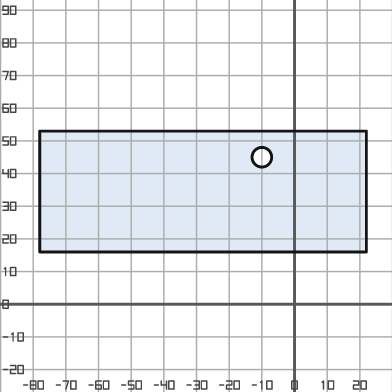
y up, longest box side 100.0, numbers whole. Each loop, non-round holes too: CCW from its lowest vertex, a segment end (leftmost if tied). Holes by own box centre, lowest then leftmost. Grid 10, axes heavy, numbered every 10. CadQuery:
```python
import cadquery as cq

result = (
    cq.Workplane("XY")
    .moveTo(-78.0, 16.0)
    .lineTo(22.0, 16.0)
    .lineTo(22.0, 53.0)
    .lineTo(-78.0, 53.0)
    .close()
    .moveTo(-10.0, 45.0)
    .circle(3.0)
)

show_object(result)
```